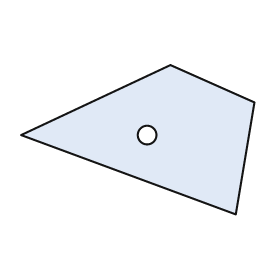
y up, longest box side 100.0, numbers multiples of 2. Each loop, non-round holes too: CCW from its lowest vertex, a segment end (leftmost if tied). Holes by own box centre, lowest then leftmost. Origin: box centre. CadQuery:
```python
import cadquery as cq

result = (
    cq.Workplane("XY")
    .moveTo(42.0, -32.0)
    .lineTo(50.0, 16.0)
    .lineTo(14.0, 32.0)
    .lineTo(-50.0, 2.0)
    .close()
    .moveTo(4.0, 2.0)
    .circle(4.0)
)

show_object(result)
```